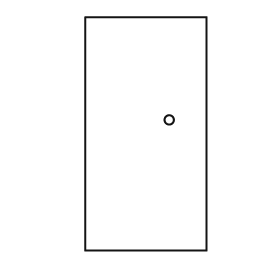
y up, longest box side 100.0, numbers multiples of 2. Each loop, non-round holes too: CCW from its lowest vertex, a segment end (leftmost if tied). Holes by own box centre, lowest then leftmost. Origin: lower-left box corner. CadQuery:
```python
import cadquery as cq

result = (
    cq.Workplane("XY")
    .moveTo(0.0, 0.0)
    .lineTo(52.0, 0.0)
    .lineTo(52.0, 100.0)
    .lineTo(0.0, 100.0)
    .close()
    .moveTo(36.0, 56.0)
    .circle(2.0)
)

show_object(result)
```